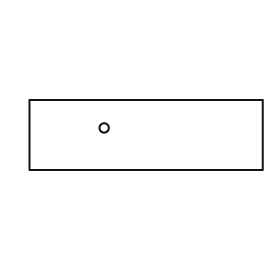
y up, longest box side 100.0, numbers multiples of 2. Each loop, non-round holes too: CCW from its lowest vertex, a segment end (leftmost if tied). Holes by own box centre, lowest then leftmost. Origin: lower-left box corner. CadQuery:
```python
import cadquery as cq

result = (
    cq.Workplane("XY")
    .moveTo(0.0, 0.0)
    .lineTo(100.0, 0.0)
    .lineTo(100.0, 30.0)
    .lineTo(0.0, 30.0)
    .close()
    .moveTo(32.0, 18.0)
    .circle(2.0)
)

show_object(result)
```